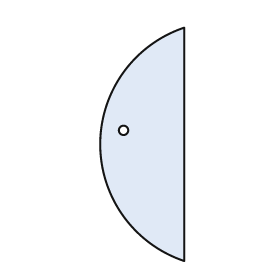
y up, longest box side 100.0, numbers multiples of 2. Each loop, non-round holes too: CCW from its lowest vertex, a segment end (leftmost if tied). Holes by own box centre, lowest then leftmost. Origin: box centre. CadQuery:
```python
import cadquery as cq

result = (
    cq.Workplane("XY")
    .moveTo(18.0, -50.0)
    .lineTo(18.0, 50.0)
    .threePointArc((-18.0, 0.0), (18.0, -50.0))
    .close()
    .moveTo(-8.0, 6.0)
    .circle(2.0)
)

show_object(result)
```